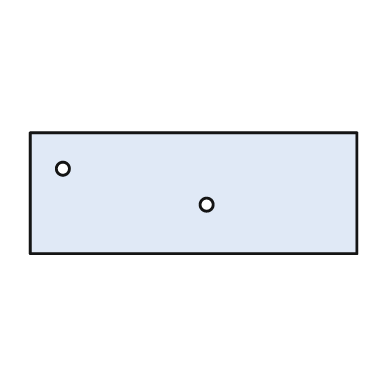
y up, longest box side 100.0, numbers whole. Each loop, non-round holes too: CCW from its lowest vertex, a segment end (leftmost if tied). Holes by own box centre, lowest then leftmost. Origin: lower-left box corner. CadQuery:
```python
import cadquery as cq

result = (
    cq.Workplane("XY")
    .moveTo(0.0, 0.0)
    .lineTo(100.0, 0.0)
    .lineTo(100.0, 37.0)
    .lineTo(0.0, 37.0)
    .close()
    .moveTo(54.0, 15.0)
    .circle(2.0)
    .moveTo(10.0, 26.0)
    .circle(2.0)
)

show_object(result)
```